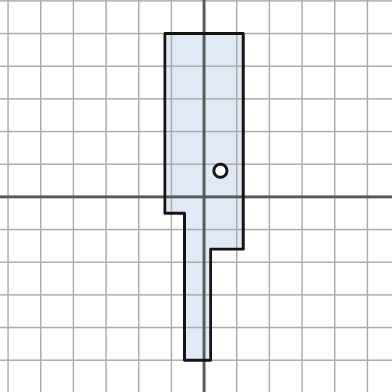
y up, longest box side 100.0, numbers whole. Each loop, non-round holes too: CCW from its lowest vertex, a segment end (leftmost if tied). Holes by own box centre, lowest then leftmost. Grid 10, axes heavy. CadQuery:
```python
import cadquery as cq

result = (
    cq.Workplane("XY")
    .moveTo(-6.0, -50.0)
    .lineTo(2.0, -50.0)
    .lineTo(2.0, -16.0)
    .lineTo(12.0, -16.0)
    .lineTo(12.0, 50.0)
    .lineTo(-12.0, 50.0)
    .lineTo(-12.0, -5.0)
    .lineTo(-6.0, -5.0)
    .close()
    .moveTo(5.0, 8.0)
    .circle(2.0)
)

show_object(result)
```